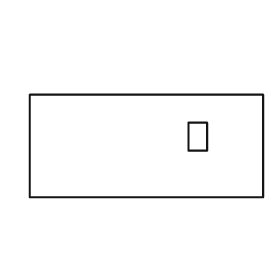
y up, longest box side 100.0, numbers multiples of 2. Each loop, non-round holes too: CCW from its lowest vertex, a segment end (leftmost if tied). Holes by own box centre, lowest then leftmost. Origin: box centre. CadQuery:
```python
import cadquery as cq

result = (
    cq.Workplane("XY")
    .moveTo(-50.0, -22.0)
    .lineTo(50.0, -22.0)
    .lineTo(50.0, 22.0)
    .lineTo(-50.0, 22.0)
    .close()
    .moveTo(18.0, -2.0)
    .lineTo(26.0, -2.0)
    .lineTo(26.0, 10.0)
    .lineTo(18.0, 10.0)
    .close()
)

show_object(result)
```